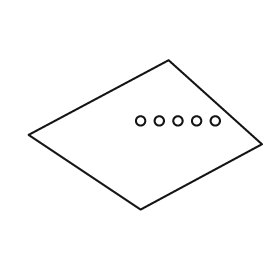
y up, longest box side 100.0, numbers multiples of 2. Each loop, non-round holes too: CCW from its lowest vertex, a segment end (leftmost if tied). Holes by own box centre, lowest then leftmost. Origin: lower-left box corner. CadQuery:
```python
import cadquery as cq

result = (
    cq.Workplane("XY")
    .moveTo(48.0, 0.0)
    .lineTo(100.0, 28.0)
    .lineTo(60.0, 64.0)
    .lineTo(0.0, 32.0)
    .close()
    .moveTo(48.0, 38.0)
    .circle(2.0)
    .moveTo(56.0, 38.0)
    .circle(2.0)
    .moveTo(64.0, 38.0)
    .circle(2.0)
    .moveTo(72.0, 38.0)
    .circle(2.0)
    .moveTo(80.0, 38.0)
    .circle(2.0)
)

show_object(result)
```